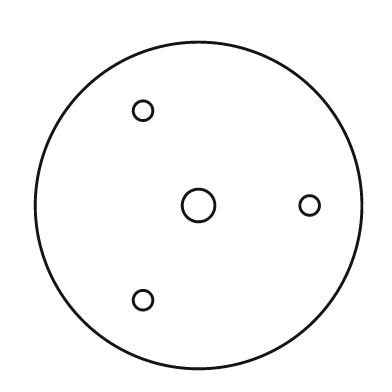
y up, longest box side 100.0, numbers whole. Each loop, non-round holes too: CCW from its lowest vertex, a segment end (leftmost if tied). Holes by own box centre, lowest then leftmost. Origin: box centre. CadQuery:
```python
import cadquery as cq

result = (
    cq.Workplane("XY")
    .moveTo(0.0, 0.0)
    .circle(50.0)
    .moveTo(-17.0, -29.0)
    .circle(3.0)
    .moveTo(0.0, 0.0)
    .circle(5.0)
    .moveTo(34.0, 0.0)
    .circle(3.0)
    .moveTo(-17.0, 29.0)
    .circle(3.0)
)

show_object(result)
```